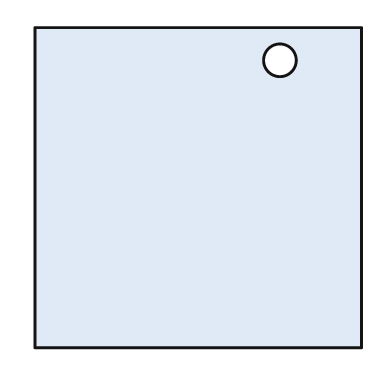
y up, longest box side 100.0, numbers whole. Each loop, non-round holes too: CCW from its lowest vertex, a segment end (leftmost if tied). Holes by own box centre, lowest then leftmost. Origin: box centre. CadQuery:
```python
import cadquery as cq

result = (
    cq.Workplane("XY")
    .moveTo(-50.0, -49.0)
    .lineTo(50.0, -49.0)
    .lineTo(50.0, 49.0)
    .lineTo(-50.0, 49.0)
    .close()
    .moveTo(25.0, 39.0)
    .circle(5.0)
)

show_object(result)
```